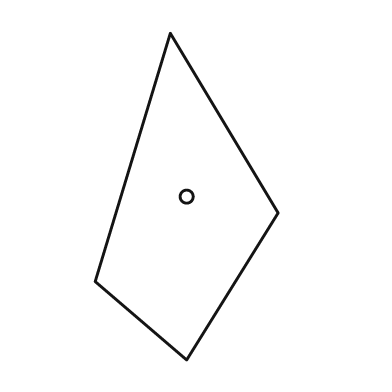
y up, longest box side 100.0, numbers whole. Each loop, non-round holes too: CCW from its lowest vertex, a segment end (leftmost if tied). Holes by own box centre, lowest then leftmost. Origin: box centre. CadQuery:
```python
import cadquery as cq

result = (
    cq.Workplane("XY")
    .moveTo(0.0, -50.0)
    .lineTo(28.0, -5.0)
    .lineTo(-5.0, 50.0)
    .lineTo(-28.0, -26.0)
    .close()
    .moveTo(0.0, 0.0)
    .circle(2.0)
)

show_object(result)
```